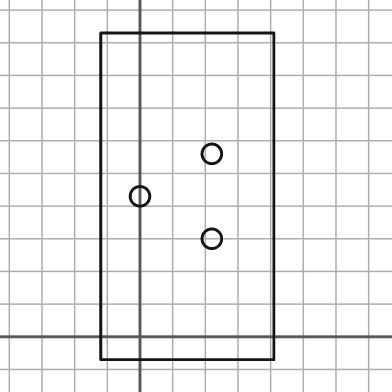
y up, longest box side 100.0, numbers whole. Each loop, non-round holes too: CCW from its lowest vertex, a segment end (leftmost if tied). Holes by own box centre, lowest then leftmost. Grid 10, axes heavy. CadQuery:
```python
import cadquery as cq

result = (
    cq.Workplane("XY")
    .moveTo(-12.0, -7.0)
    .lineTo(41.0, -7.0)
    .lineTo(41.0, 93.0)
    .lineTo(-12.0, 93.0)
    .close()
    .moveTo(22.0, 30.0)
    .circle(3.0)
    .moveTo(0.0, 43.0)
    .circle(3.0)
    .moveTo(22.0, 56.0)
    .circle(3.0)
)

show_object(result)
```